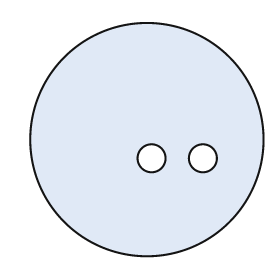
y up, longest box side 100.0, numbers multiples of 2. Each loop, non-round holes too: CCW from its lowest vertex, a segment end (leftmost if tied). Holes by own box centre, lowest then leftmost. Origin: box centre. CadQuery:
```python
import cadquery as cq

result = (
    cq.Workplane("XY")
    .moveTo(0.0, 0.0)
    .circle(50.0)
    .moveTo(2.0, -8.0)
    .circle(6.0)
    .moveTo(24.0, -8.0)
    .circle(6.0)
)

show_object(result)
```